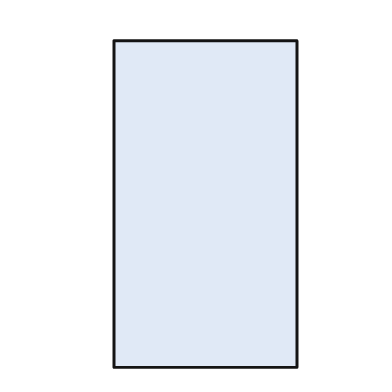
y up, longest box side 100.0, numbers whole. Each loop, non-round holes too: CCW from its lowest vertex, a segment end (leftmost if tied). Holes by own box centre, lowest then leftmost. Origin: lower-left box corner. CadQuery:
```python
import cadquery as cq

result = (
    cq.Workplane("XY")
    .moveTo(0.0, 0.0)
    .lineTo(56.0, 0.0)
    .lineTo(56.0, 100.0)
    .lineTo(0.0, 100.0)
    .close()
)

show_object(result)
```